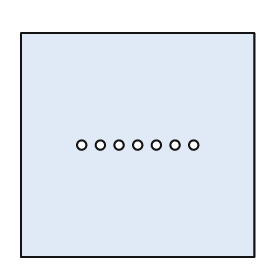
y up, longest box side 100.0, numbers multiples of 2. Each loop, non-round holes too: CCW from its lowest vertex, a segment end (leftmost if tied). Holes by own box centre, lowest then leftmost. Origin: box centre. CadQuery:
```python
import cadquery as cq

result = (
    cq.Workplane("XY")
    .moveTo(-50.0, -48.0)
    .lineTo(50.0, -48.0)
    .lineTo(50.0, 48.0)
    .lineTo(-50.0, 48.0)
    .close()
    .moveTo(-24.0, 0.0)
    .circle(2.0)
    .moveTo(-16.0, 0.0)
    .circle(2.0)
    .moveTo(-8.0, 0.0)
    .circle(2.0)
    .moveTo(0.0, 0.0)
    .circle(2.0)
    .moveTo(8.0, 0.0)
    .circle(2.0)
    .moveTo(16.0, 0.0)
    .circle(2.0)
    .moveTo(24.0, 0.0)
    .circle(2.0)
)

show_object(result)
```